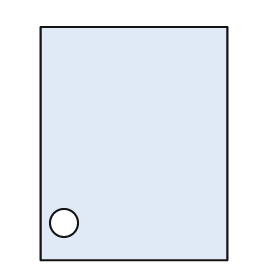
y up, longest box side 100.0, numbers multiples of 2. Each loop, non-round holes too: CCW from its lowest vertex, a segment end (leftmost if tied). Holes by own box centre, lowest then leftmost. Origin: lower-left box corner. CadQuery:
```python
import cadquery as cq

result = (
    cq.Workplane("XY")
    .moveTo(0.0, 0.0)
    .lineTo(80.0, 0.0)
    .lineTo(80.0, 100.0)
    .lineTo(0.0, 100.0)
    .close()
    .moveTo(10.0, 16.0)
    .circle(6.0)
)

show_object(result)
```